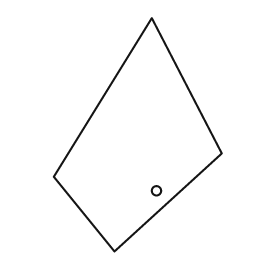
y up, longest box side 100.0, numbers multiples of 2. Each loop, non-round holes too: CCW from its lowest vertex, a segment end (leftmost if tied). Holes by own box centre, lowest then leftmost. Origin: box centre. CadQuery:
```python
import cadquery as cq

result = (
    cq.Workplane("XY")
    .moveTo(-10.0, -50.0)
    .lineTo(36.0, -8.0)
    .lineTo(6.0, 50.0)
    .lineTo(-36.0, -18.0)
    .close()
    .moveTo(8.0, -24.0)
    .circle(2.0)
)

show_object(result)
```